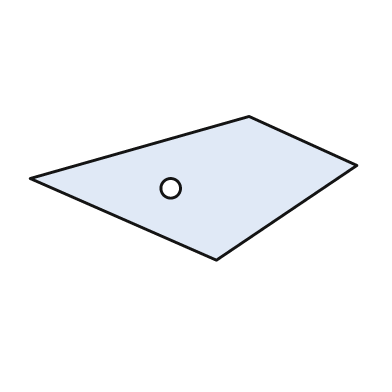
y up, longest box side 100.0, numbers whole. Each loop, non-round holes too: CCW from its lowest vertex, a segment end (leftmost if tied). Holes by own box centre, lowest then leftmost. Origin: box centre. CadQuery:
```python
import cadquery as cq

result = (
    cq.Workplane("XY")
    .moveTo(7.0, -22.0)
    .lineTo(50.0, 7.0)
    .lineTo(17.0, 22.0)
    .lineTo(-50.0, 3.0)
    .close()
    .moveTo(-7.0, 0.0)
    .circle(3.0)
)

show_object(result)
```